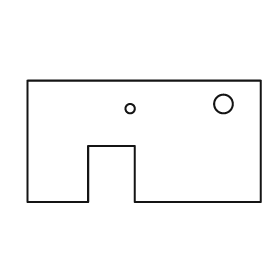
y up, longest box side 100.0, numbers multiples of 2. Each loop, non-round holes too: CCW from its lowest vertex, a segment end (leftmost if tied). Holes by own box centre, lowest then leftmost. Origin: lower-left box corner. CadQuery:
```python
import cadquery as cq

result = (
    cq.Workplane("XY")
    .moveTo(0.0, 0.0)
    .lineTo(26.0, 0.0)
    .lineTo(26.0, 24.0)
    .lineTo(46.0, 24.0)
    .lineTo(46.0, 0.0)
    .lineTo(100.0, 0.0)
    .lineTo(100.0, 52.0)
    .lineTo(0.0, 52.0)
    .close()
    .moveTo(44.0, 40.0)
    .circle(2.0)
    .moveTo(84.0, 42.0)
    .circle(4.0)
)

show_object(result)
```